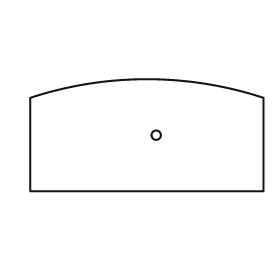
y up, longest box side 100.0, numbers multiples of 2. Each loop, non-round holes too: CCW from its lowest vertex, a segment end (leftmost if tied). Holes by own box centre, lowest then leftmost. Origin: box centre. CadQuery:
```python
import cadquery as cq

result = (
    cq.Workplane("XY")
    .moveTo(-50.0, -24.0)
    .lineTo(50.0, -24.0)
    .lineTo(50.0, 16.0)
    .threePointArc((0.0, 24.0), (-50.0, 16.0))
    .close()
    .moveTo(4.0, 0.0)
    .circle(2.0)
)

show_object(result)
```